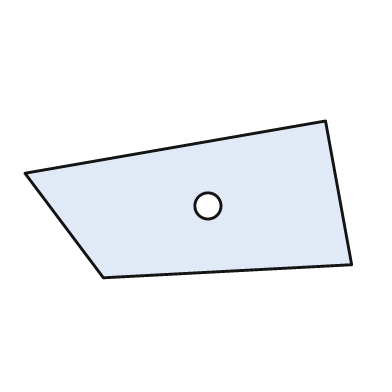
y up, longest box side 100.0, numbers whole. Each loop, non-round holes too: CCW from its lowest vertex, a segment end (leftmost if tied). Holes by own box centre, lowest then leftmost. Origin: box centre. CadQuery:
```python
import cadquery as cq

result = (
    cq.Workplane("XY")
    .moveTo(-26.0, -24.0)
    .lineTo(50.0, -20.0)
    .lineTo(42.0, 24.0)
    .lineTo(-50.0, 8.0)
    .close()
    .moveTo(6.0, -2.0)
    .circle(4.0)
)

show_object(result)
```